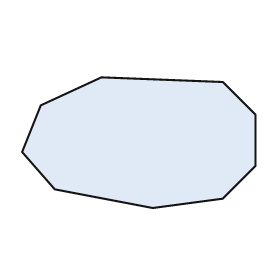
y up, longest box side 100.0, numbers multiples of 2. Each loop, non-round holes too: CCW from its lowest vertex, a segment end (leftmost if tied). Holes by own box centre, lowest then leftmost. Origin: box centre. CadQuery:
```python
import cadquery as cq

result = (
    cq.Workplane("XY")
    .moveTo(6.0, -28.0)
    .lineTo(36.0, -24.0)
    .lineTo(50.0, -10.0)
    .lineTo(50.0, 12.0)
    .lineTo(36.0, 26.0)
    .lineTo(-16.0, 28.0)
    .lineTo(-42.0, 16.0)
    .lineTo(-50.0, -4.0)
    .lineTo(-36.0, -20.0)
    .close()
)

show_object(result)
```